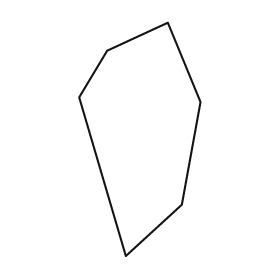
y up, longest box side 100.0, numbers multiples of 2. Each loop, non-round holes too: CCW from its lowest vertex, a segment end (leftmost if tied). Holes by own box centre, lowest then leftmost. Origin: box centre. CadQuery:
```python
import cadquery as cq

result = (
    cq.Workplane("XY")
    .moveTo(-6.0, -50.0)
    .lineTo(18.0, -28.0)
    .lineTo(26.0, 16.0)
    .lineTo(12.0, 50.0)
    .lineTo(-14.0, 38.0)
    .lineTo(-26.0, 18.0)
    .close()
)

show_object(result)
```